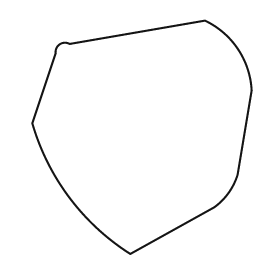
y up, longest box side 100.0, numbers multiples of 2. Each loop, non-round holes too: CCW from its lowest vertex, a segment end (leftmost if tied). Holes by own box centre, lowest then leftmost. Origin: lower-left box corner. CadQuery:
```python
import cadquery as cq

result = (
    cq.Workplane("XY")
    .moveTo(42.0, 0.0)
    .lineTo(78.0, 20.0)
    .threePointArc((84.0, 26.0), (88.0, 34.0))
    .lineTo(94.0, 70.0)
    .threePointArc((88.0, 88.0), (74.0, 100.0))
    .lineTo(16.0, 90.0)
    .threePointArc((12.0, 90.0), (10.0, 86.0))
    .lineTo(0.0, 56.0)
    .threePointArc((16.0, 24.0), (42.0, 0.0))
    .close()
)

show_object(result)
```